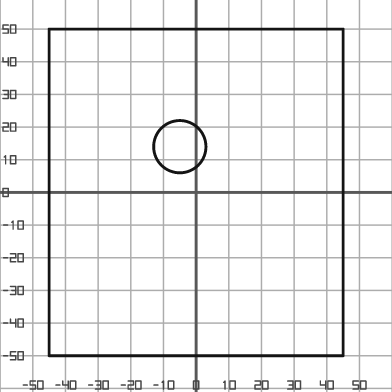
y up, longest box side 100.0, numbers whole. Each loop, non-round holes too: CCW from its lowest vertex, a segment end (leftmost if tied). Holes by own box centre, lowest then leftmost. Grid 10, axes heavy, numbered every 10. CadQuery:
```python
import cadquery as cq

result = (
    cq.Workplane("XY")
    .moveTo(-45.0, -50.0)
    .lineTo(45.0, -50.0)
    .lineTo(45.0, 50.0)
    .lineTo(-45.0, 50.0)
    .close()
    .moveTo(-5.0, 14.0)
    .circle(8.0)
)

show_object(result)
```